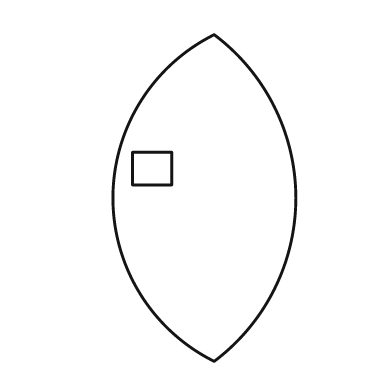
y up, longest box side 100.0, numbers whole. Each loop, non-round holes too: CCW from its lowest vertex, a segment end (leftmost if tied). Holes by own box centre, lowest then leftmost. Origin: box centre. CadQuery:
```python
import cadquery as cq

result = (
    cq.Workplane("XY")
    .moveTo(3.0, -50.0)
    .threePointArc((28.0, 0.0), (3.0, 50.0))
    .threePointArc((-28.0, 0.0), (3.0, -50.0))
    .close()
    .moveTo(-22.0, 4.0)
    .lineTo(-10.0, 4.0)
    .lineTo(-10.0, 14.0)
    .lineTo(-22.0, 14.0)
    .close()
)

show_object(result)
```